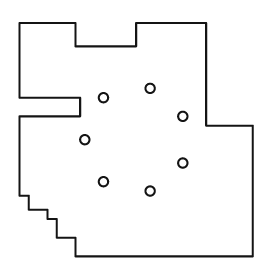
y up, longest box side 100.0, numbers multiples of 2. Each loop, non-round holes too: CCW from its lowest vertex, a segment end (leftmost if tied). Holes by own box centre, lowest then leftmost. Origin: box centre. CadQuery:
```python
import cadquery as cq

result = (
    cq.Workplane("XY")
    .moveTo(-26.0, -50.0)
    .lineTo(50.0, -50.0)
    .lineTo(50.0, 6.0)
    .lineTo(30.0, 6.0)
    .lineTo(30.0, 50.0)
    .lineTo(0.0, 50.0)
    .lineTo(0.0, 40.0)
    .lineTo(-26.0, 40.0)
    .lineTo(-26.0, 50.0)
    .lineTo(-50.0, 50.0)
    .lineTo(-50.0, 18.0)
    .lineTo(-24.0, 18.0)
    .lineTo(-24.0, 10.0)
    .lineTo(-50.0, 10.0)
    .lineTo(-50.0, -24.0)
    .lineTo(-46.0, -24.0)
    .lineTo(-46.0, -30.0)
    .lineTo(-38.0, -30.0)
    .lineTo(-38.0, -34.0)
    .lineTo(-34.0, -34.0)
    .lineTo(-34.0, -42.0)
    .lineTo(-26.0, -42.0)
    .close()
    .moveTo(6.0, -22.0)
    .circle(2.0)
    .moveTo(-14.0, -18.0)
    .circle(2.0)
    .moveTo(20.0, -10.0)
    .circle(2.0)
    .moveTo(-22.0, 0.0)
    .circle(2.0)
    .moveTo(20.0, 10.0)
    .circle(2.0)
    .moveTo(-14.0, 18.0)
    .circle(2.0)
    .moveTo(6.0, 22.0)
    .circle(2.0)
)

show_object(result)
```